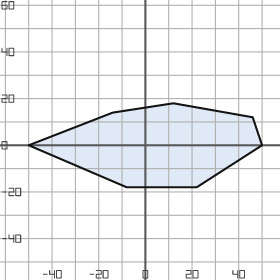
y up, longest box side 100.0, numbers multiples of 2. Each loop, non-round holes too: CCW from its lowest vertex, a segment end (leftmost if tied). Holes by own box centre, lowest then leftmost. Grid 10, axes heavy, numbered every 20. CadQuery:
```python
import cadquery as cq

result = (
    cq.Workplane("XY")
    .moveTo(-8.0, -18.0)
    .lineTo(22.0, -18.0)
    .lineTo(50.0, 0.0)
    .lineTo(46.0, 12.0)
    .lineTo(12.0, 18.0)
    .lineTo(-14.0, 14.0)
    .lineTo(-50.0, 0.0)
    .close()
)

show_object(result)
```